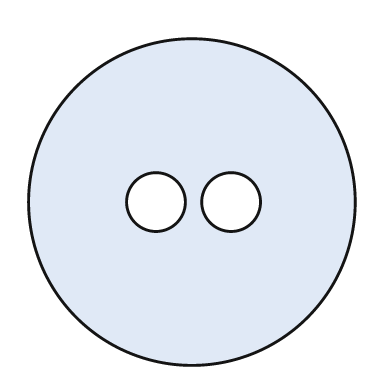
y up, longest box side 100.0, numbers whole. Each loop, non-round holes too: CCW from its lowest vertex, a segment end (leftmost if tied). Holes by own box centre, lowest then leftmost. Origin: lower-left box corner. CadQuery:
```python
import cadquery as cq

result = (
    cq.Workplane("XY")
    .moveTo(50.0, 50.0)
    .circle(50.0)
    .moveTo(39.0, 50.0)
    .circle(9.0)
    .moveTo(62.0, 50.0)
    .circle(9.0)
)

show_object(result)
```